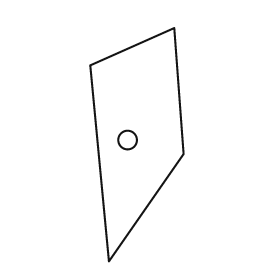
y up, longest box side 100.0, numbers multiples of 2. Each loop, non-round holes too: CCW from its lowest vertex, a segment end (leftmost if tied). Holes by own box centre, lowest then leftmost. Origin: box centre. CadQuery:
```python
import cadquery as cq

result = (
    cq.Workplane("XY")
    .moveTo(-12.0, -50.0)
    .lineTo(20.0, -4.0)
    .lineTo(16.0, 50.0)
    .lineTo(-20.0, 34.0)
    .close()
    .moveTo(-4.0, 2.0)
    .circle(4.0)
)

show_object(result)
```